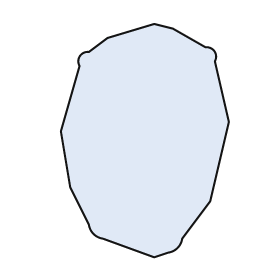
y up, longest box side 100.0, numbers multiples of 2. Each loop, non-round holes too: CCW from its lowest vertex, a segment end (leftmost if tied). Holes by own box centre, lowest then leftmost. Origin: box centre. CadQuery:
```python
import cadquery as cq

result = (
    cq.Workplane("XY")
    .moveTo(4.0, -50.0)
    .lineTo(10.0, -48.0)
    .threePointArc((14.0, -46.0), (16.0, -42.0))
    .lineTo(28.0, -26.0)
    .lineTo(36.0, 8.0)
    .lineTo(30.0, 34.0)
    .threePointArc((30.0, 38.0), (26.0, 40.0))
    .lineTo(12.0, 48.0)
    .lineTo(4.0, 50.0)
    .lineTo(-16.0, 44.0)
    .lineTo(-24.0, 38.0)
    .threePointArc((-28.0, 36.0), (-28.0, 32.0))
    .lineTo(-36.0, 4.0)
    .lineTo(-32.0, -20.0)
    .lineTo(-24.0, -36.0)
    .threePointArc((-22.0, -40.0), (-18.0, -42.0))
    .close()
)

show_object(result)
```